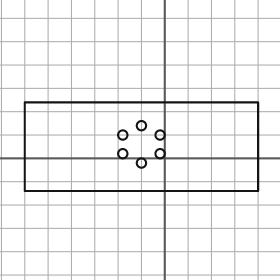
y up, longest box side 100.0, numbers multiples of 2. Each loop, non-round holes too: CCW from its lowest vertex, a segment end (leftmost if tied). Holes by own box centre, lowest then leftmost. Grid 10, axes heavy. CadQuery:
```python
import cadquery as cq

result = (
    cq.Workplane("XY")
    .moveTo(-60.0, -14.0)
    .lineTo(40.0, -14.0)
    .lineTo(40.0, 24.0)
    .lineTo(-60.0, 24.0)
    .close()
    .moveTo(-10.0, -2.0)
    .circle(2.0)
    .moveTo(-18.0, 2.0)
    .circle(2.0)
    .moveTo(-2.0, 2.0)
    .circle(2.0)
    .moveTo(-18.0, 10.0)
    .circle(2.0)
    .moveTo(-2.0, 10.0)
    .circle(2.0)
    .moveTo(-10.0, 14.0)
    .circle(2.0)
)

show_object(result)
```